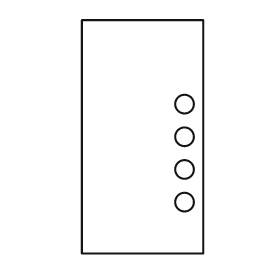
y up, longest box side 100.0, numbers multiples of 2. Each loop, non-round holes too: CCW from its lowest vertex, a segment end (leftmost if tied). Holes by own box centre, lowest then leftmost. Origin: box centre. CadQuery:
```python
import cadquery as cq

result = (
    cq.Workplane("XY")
    .moveTo(-26.0, -50.0)
    .lineTo(26.0, -50.0)
    .lineTo(26.0, 50.0)
    .lineTo(-26.0, 50.0)
    .close()
    .moveTo(18.0, -28.0)
    .circle(4.0)
    .moveTo(18.0, -14.0)
    .circle(4.0)
    .moveTo(18.0, 0.0)
    .circle(4.0)
    .moveTo(18.0, 14.0)
    .circle(4.0)
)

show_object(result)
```